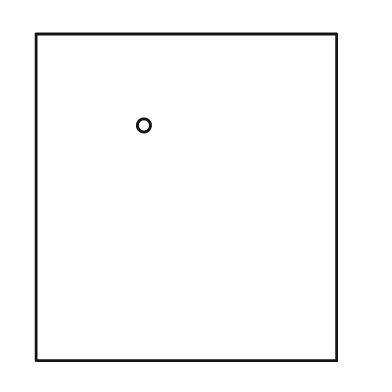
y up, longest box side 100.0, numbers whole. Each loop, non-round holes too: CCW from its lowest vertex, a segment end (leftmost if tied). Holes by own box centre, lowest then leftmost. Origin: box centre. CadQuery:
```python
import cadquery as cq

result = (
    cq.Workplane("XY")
    .moveTo(-46.0, -50.0)
    .lineTo(46.0, -50.0)
    .lineTo(46.0, 50.0)
    .lineTo(-46.0, 50.0)
    .close()
    .moveTo(-13.0, 22.0)
    .circle(2.0)
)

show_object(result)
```